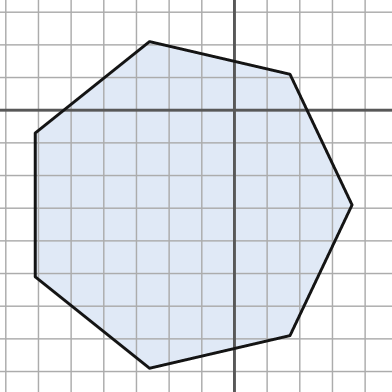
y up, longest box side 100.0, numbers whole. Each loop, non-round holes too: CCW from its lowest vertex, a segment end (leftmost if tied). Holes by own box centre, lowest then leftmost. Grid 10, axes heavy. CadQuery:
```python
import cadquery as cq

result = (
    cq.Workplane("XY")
    .moveTo(-26.0, -79.0)
    .lineTo(17.0, -69.0)
    .lineTo(36.0, -29.0)
    .lineTo(17.0, 11.0)
    .lineTo(-26.0, 21.0)
    .lineTo(-61.0, -7.0)
    .lineTo(-61.0, -51.0)
    .close()
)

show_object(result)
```